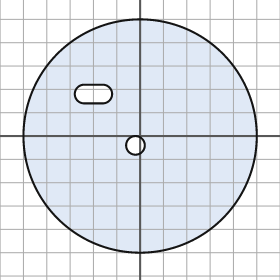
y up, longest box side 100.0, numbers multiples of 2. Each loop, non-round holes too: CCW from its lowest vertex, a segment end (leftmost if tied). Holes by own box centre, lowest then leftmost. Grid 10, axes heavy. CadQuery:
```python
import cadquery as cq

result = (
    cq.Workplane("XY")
    .moveTo(0.0, 0.0)
    .circle(50.0)
    .moveTo(-2.0, -4.0)
    .circle(4.0)
    .moveTo(-24.0, 14.0)
    .lineTo(-16.0, 14.0)
    .threePointArc((-12.0, 18.0), (-16.0, 22.0))
    .lineTo(-24.0, 22.0)
    .threePointArc((-28.0, 18.0), (-24.0, 14.0))
    .close()
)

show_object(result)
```